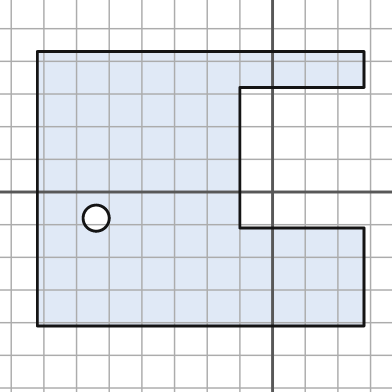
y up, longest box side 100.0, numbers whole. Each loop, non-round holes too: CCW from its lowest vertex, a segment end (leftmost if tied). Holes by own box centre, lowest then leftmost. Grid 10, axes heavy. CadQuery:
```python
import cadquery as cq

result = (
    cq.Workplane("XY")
    .moveTo(-72.0, -41.0)
    .lineTo(28.0, -41.0)
    .lineTo(28.0, -11.0)
    .lineTo(-10.0, -11.0)
    .lineTo(-10.0, 32.0)
    .lineTo(28.0, 32.0)
    .lineTo(28.0, 43.0)
    .lineTo(-72.0, 43.0)
    .close()
    .moveTo(-54.0, -8.0)
    .circle(4.0)
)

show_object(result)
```